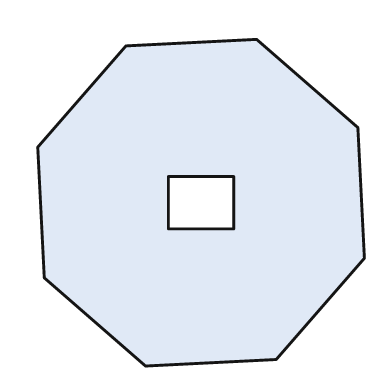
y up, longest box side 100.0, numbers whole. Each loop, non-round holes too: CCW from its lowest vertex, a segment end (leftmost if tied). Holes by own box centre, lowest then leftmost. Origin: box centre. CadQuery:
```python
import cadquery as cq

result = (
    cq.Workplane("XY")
    .moveTo(-17.0, -50.0)
    .lineTo(23.0, -48.0)
    .lineTo(50.0, -17.0)
    .lineTo(48.0, 23.0)
    .lineTo(17.0, 50.0)
    .lineTo(-23.0, 48.0)
    .lineTo(-50.0, 17.0)
    .lineTo(-48.0, -23.0)
    .close()
    .moveTo(-10.0, -8.0)
    .lineTo(10.0, -8.0)
    .lineTo(10.0, 8.0)
    .lineTo(-10.0, 8.0)
    .close()
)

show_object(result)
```